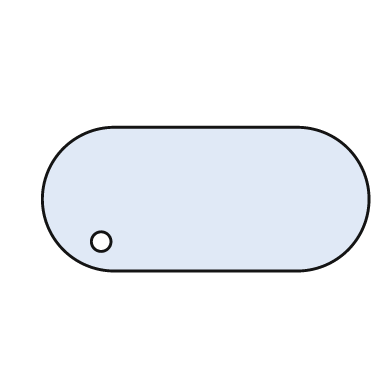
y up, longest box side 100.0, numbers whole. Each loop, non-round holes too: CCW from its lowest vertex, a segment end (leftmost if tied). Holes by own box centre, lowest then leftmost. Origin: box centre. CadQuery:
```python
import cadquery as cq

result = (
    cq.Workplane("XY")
    .moveTo(-28.0, -22.0)
    .lineTo(28.0, -22.0)
    .threePointArc((50.0, 0.0), (28.0, 22.0))
    .lineTo(-28.0, 22.0)
    .threePointArc((-50.0, 0.0), (-28.0, -22.0))
    .close()
    .moveTo(-32.0, -13.0)
    .circle(3.0)
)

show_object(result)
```